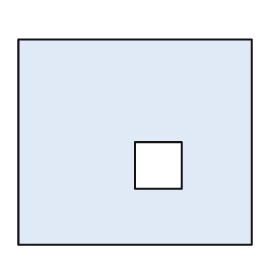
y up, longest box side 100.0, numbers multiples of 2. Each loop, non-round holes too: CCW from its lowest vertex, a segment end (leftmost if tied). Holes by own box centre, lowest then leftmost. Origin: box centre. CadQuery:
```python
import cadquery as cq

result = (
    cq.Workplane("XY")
    .moveTo(-50.0, -44.0)
    .lineTo(50.0, -44.0)
    .lineTo(50.0, 44.0)
    .lineTo(-50.0, 44.0)
    .close()
    .moveTo(0.0, -20.0)
    .lineTo(20.0, -20.0)
    .lineTo(20.0, 0.0)
    .lineTo(0.0, 0.0)
    .close()
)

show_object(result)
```